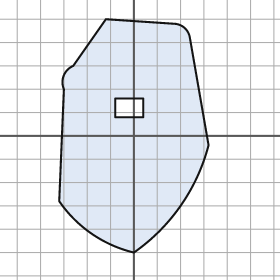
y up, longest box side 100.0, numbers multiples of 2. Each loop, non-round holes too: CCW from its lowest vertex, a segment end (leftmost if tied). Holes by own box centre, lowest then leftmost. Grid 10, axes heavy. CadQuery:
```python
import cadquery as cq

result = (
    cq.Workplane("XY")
    .moveTo(0.0, -50.0)
    .threePointArc((20.0, -30.0), (32.0, -4.0))
    .lineTo(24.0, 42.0)
    .threePointArc((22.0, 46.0), (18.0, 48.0))
    .lineTo(-12.0, 50.0)
    .lineTo(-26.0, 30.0)
    .threePointArc((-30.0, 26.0), (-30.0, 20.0))
    .lineTo(-32.0, -28.0)
    .threePointArc((-18.0, -42.0), (0.0, -50.0))
    .close()
    .moveTo(-8.0, 8.0)
    .lineTo(4.0, 8.0)
    .lineTo(4.0, 16.0)
    .lineTo(-8.0, 16.0)
    .close()
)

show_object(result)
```